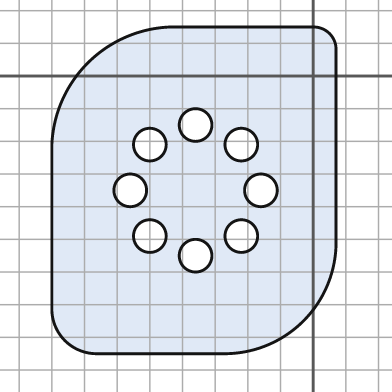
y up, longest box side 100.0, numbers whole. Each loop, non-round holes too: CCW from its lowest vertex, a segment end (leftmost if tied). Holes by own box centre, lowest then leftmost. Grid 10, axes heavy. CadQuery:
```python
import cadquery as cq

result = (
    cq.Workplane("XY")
    .moveTo(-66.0, -85.0)
    .lineTo(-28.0, -85.0)
    .threePointArc((-3.0, -75.0), (7.0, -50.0))
    .lineTo(7.0, 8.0)
    .threePointArc((5.0, 13.0), (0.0, 15.0))
    .lineTo(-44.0, 15.0)
    .threePointArc((-69.0, 4.0), (-80.0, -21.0))
    .lineTo(-80.0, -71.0)
    .threePointArc((-76.0, -81.0), (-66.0, -85.0))
    .close()
    .moveTo(-36.0, -55.0)
    .circle(5.0)
    .moveTo(-50.0, -49.0)
    .circle(5.0)
    .moveTo(-22.0, -49.0)
    .circle(5.0)
    .moveTo(-56.0, -35.0)
    .circle(5.0)
    .moveTo(-16.0, -35.0)
    .circle(5.0)
    .moveTo(-50.0, -21.0)
    .circle(5.0)
    .moveTo(-22.0, -21.0)
    .circle(5.0)
    .moveTo(-36.0, -15.0)
    .circle(5.0)
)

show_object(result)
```